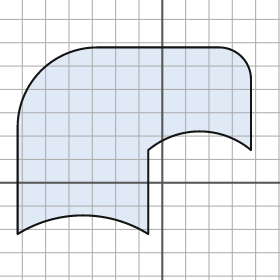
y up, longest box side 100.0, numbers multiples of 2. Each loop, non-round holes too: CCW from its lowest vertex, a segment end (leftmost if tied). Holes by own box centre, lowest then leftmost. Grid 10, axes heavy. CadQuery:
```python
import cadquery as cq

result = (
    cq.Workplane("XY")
    .moveTo(-62.0, -22.0)
    .threePointArc((-34.0, -14.0), (-6.0, -22.0))
    .lineTo(-6.0, 14.0)
    .threePointArc((16.0, 22.0), (38.0, 14.0))
    .lineTo(38.0, 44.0)
    .threePointArc((34.0, 54.0), (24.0, 58.0))
    .lineTo(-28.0, 58.0)
    .threePointArc((-52.0, 48.0), (-62.0, 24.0))
    .close()
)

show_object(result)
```